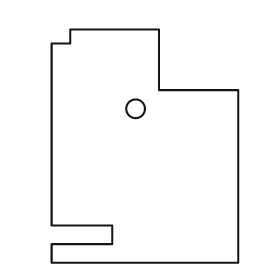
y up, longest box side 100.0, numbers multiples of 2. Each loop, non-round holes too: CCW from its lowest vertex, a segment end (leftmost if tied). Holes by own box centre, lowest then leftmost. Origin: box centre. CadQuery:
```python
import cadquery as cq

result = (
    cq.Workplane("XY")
    .moveTo(-40.0, -50.0)
    .lineTo(40.0, -50.0)
    .lineTo(40.0, 24.0)
    .lineTo(6.0, 24.0)
    .lineTo(6.0, 50.0)
    .lineTo(-32.0, 50.0)
    .lineTo(-32.0, 44.0)
    .lineTo(-40.0, 44.0)
    .lineTo(-40.0, -34.0)
    .lineTo(-14.0, -34.0)
    .lineTo(-14.0, -42.0)
    .lineTo(-40.0, -42.0)
    .close()
    .moveTo(-4.0, 16.0)
    .circle(4.0)
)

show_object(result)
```